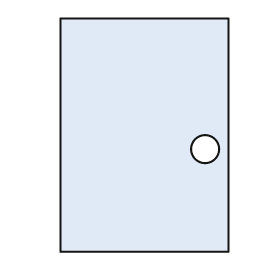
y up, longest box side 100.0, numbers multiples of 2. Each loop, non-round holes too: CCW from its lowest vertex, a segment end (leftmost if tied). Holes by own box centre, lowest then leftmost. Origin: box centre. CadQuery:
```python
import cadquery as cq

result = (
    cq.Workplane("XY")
    .moveTo(-36.0, -50.0)
    .lineTo(36.0, -50.0)
    .lineTo(36.0, 50.0)
    .lineTo(-36.0, 50.0)
    .close()
    .moveTo(26.0, -6.0)
    .circle(6.0)
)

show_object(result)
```